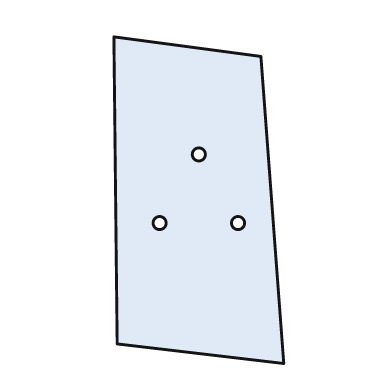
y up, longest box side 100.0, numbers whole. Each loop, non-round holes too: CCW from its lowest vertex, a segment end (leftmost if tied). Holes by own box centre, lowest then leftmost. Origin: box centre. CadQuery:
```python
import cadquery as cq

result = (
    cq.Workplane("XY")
    .moveTo(26.0, -50.0)
    .lineTo(19.0, 44.0)
    .lineTo(-26.0, 50.0)
    .lineTo(-25.0, -44.0)
    .close()
    .moveTo(-12.0, -7.0)
    .circle(2.0)
    .moveTo(12.0, -7.0)
    .circle(2.0)
    .moveTo(0.0, 14.0)
    .circle(2.0)
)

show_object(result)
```